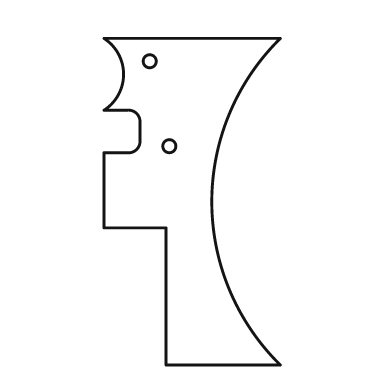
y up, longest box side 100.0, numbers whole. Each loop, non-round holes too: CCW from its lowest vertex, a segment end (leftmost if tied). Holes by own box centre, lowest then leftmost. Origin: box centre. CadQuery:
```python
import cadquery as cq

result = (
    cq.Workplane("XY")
    .moveTo(-8.0, -50.0)
    .lineTo(27.0, -50.0)
    .threePointArc((6.0, 0.0), (27.0, 50.0))
    .lineTo(-27.0, 50.0)
    .threePointArc((-21.0, 39.0), (-27.0, 28.0))
    .lineTo(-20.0, 28.0)
    .threePointArc((-17.0, 27.0), (-16.0, 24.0))
    .lineTo(-16.0, 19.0)
    .threePointArc((-17.0, 16.0), (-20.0, 15.0))
    .lineTo(-27.0, 15.0)
    .lineTo(-27.0, -8.0)
    .lineTo(-8.0, -8.0)
    .close()
    .moveTo(-7.0, 17.0)
    .circle(2.0)
    .moveTo(-13.0, 43.0)
    .circle(2.0)
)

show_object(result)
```